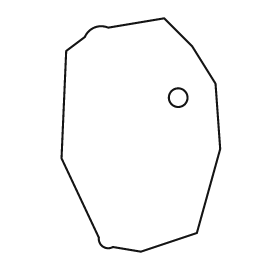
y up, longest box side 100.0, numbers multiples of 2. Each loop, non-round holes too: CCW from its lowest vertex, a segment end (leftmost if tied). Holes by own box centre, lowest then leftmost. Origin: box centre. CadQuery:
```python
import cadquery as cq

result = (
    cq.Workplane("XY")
    .moveTo(0.0, -50.0)
    .lineTo(24.0, -42.0)
    .lineTo(34.0, -6.0)
    .lineTo(32.0, 22.0)
    .lineTo(22.0, 38.0)
    .lineTo(10.0, 50.0)
    .lineTo(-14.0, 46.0)
    .threePointArc((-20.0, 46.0), (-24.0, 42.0))
    .lineTo(-32.0, 36.0)
    .lineTo(-34.0, -10.0)
    .lineTo(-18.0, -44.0)
    .threePointArc((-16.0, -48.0), (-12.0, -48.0))
    .close()
    .moveTo(16.0, 16.0)
    .circle(4.0)
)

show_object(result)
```